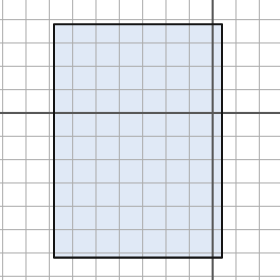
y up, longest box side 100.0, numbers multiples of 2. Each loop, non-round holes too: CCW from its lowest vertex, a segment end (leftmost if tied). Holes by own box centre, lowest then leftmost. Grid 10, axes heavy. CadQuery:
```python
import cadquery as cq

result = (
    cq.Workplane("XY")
    .moveTo(-68.0, -62.0)
    .lineTo(4.0, -62.0)
    .lineTo(4.0, 38.0)
    .lineTo(-68.0, 38.0)
    .close()
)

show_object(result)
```